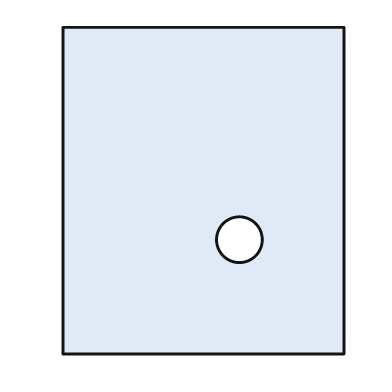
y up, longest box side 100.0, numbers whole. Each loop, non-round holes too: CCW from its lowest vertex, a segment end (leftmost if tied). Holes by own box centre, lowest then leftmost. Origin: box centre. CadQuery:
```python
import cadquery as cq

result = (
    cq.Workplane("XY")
    .moveTo(-43.0, -50.0)
    .lineTo(43.0, -50.0)
    .lineTo(43.0, 50.0)
    .lineTo(-43.0, 50.0)
    .close()
    .moveTo(11.0, -15.0)
    .circle(7.0)
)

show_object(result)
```